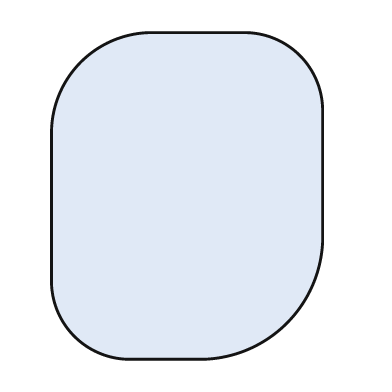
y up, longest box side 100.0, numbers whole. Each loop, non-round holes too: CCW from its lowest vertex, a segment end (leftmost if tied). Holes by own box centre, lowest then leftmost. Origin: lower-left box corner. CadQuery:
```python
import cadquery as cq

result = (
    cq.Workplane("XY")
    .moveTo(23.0, 0.0)
    .lineTo(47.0, 0.0)
    .threePointArc((72.0, 11.0), (83.0, 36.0))
    .lineTo(83.0, 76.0)
    .threePointArc((76.0, 93.0), (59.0, 100.0))
    .lineTo(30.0, 100.0)
    .threePointArc((9.0, 91.0), (0.0, 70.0))
    .lineTo(0.0, 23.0)
    .threePointArc((7.0, 7.0), (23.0, 0.0))
    .close()
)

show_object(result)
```